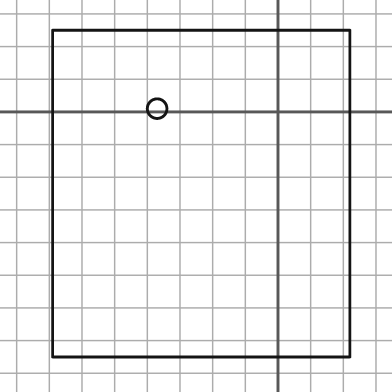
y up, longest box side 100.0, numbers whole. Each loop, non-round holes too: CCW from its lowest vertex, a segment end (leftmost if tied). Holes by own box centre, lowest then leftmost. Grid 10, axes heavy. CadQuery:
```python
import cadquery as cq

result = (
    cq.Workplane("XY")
    .moveTo(-69.0, -75.0)
    .lineTo(22.0, -75.0)
    .lineTo(22.0, 25.0)
    .lineTo(-69.0, 25.0)
    .close()
    .moveTo(-37.0, 1.0)
    .circle(3.0)
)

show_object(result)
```